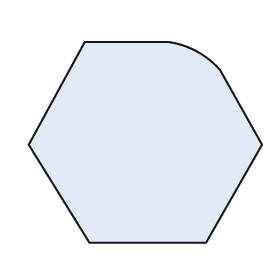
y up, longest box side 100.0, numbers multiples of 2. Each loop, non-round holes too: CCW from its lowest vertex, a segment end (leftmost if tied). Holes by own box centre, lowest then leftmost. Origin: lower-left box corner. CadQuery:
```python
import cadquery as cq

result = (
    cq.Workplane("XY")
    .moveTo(26.0, 0.0)
    .lineTo(76.0, 0.0)
    .lineTo(100.0, 42.0)
    .lineTo(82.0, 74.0)
    .threePointArc((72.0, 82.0), (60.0, 86.0))
    .lineTo(24.0, 86.0)
    .lineTo(0.0, 42.0)
    .close()
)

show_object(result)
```